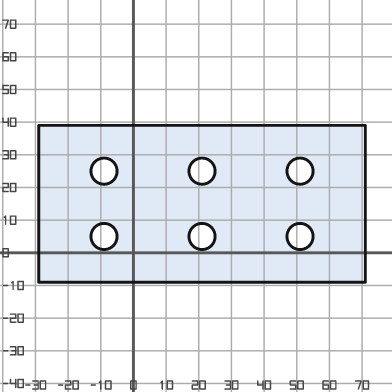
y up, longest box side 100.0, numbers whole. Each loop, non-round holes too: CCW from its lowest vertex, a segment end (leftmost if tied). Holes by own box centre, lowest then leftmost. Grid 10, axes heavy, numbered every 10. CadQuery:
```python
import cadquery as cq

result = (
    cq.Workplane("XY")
    .moveTo(-29.0, -9.0)
    .lineTo(71.0, -9.0)
    .lineTo(71.0, 39.0)
    .lineTo(-29.0, 39.0)
    .close()
    .moveTo(-9.0, 5.0)
    .circle(4.0)
    .moveTo(21.0, 5.0)
    .circle(4.0)
    .moveTo(51.0, 5.0)
    .circle(4.0)
    .moveTo(-9.0, 25.0)
    .circle(4.0)
    .moveTo(21.0, 25.0)
    .circle(4.0)
    .moveTo(51.0, 25.0)
    .circle(4.0)
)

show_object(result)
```